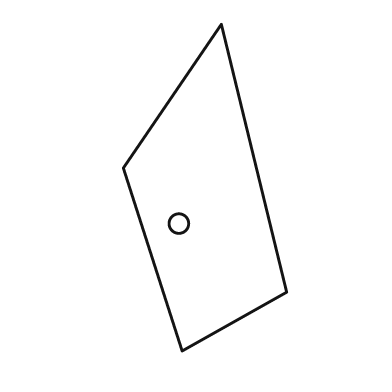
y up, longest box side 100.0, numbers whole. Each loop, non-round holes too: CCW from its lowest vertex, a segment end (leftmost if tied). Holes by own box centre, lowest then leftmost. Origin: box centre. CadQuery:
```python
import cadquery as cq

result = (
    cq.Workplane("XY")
    .moveTo(-7.0, -50.0)
    .lineTo(25.0, -32.0)
    .lineTo(5.0, 50.0)
    .lineTo(-25.0, 6.0)
    .close()
    .moveTo(-8.0, -11.0)
    .circle(3.0)
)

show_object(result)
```